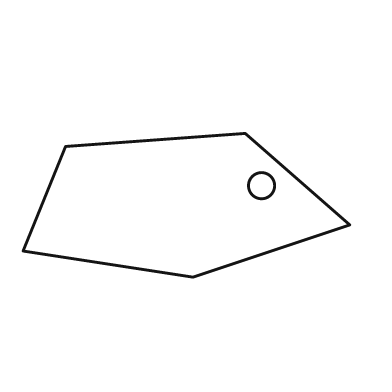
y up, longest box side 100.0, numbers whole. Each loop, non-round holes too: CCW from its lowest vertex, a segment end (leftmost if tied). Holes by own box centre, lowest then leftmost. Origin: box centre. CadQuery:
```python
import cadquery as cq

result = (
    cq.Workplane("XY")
    .moveTo(2.0, -22.0)
    .lineTo(50.0, -6.0)
    .lineTo(18.0, 22.0)
    .lineTo(-37.0, 18.0)
    .lineTo(-50.0, -14.0)
    .close()
    .moveTo(23.0, 6.0)
    .circle(4.0)
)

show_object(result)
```